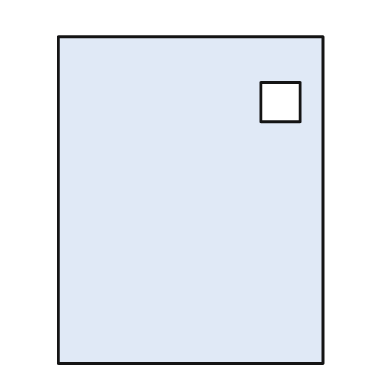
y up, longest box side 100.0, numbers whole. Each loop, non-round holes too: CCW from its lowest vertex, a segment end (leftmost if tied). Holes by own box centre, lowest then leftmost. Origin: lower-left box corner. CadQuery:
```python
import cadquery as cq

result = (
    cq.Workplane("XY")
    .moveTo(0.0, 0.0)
    .lineTo(81.0, 0.0)
    .lineTo(81.0, 100.0)
    .lineTo(0.0, 100.0)
    .close()
    .moveTo(62.0, 74.0)
    .lineTo(74.0, 74.0)
    .lineTo(74.0, 86.0)
    .lineTo(62.0, 86.0)
    .close()
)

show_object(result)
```